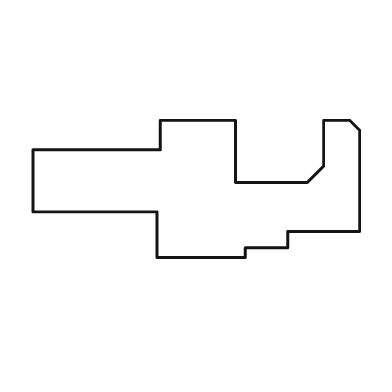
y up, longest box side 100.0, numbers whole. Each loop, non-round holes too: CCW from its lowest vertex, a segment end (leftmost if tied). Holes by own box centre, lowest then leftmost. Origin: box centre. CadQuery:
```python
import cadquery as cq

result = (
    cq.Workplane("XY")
    .moveTo(-12.0, -21.0)
    .lineTo(15.0, -21.0)
    .lineTo(15.0, -18.0)
    .lineTo(28.0, -18.0)
    .lineTo(28.0, -13.0)
    .lineTo(50.0, -13.0)
    .lineTo(50.0, 18.0)
    .lineTo(47.0, 21.0)
    .lineTo(39.0, 21.0)
    .lineTo(39.0, 7.0)
    .lineTo(34.0, 2.0)
    .lineTo(12.0, 2.0)
    .lineTo(12.0, 21.0)
    .lineTo(-11.0, 21.0)
    .lineTo(-11.0, 12.0)
    .lineTo(-50.0, 12.0)
    .lineTo(-50.0, -7.0)
    .lineTo(-12.0, -7.0)
    .close()
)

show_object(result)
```